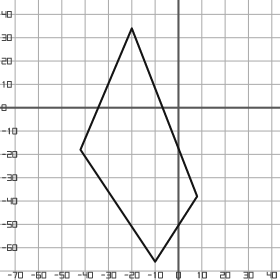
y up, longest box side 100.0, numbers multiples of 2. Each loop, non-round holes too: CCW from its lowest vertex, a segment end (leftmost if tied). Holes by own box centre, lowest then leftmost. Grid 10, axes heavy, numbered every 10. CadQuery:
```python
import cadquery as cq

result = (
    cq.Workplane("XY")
    .moveTo(-10.0, -66.0)
    .lineTo(8.0, -38.0)
    .lineTo(-20.0, 34.0)
    .lineTo(-42.0, -18.0)
    .close()
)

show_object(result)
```